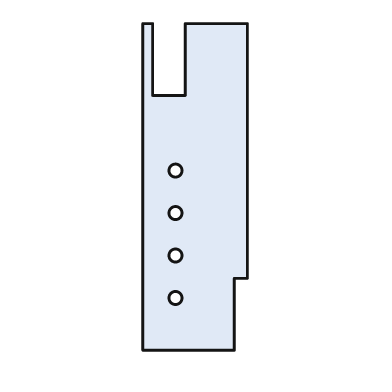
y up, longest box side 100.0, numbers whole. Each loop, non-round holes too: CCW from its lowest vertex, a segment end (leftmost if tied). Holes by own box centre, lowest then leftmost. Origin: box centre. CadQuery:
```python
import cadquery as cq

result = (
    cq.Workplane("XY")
    .moveTo(-16.0, -50.0)
    .lineTo(12.0, -50.0)
    .lineTo(12.0, -28.0)
    .lineTo(16.0, -28.0)
    .lineTo(16.0, 50.0)
    .lineTo(-3.0, 50.0)
    .lineTo(-3.0, 28.0)
    .lineTo(-13.0, 28.0)
    .lineTo(-13.0, 50.0)
    .lineTo(-16.0, 50.0)
    .close()
    .moveTo(-6.0, -34.0)
    .circle(2.0)
    .moveTo(-6.0, -21.0)
    .circle(2.0)
    .moveTo(-6.0, -8.0)
    .circle(2.0)
    .moveTo(-6.0, 5.0)
    .circle(2.0)
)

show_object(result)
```